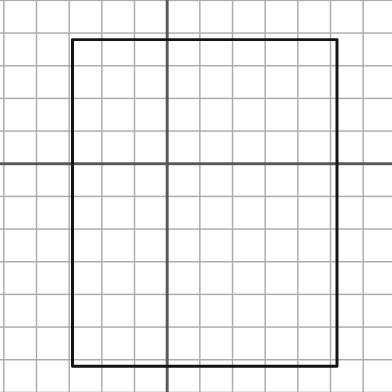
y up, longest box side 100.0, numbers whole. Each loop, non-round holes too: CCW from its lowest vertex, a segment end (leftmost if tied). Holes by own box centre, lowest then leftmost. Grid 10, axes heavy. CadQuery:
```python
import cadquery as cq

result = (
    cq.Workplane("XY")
    .moveTo(-29.0, -62.0)
    .lineTo(52.0, -62.0)
    .lineTo(52.0, 38.0)
    .lineTo(-29.0, 38.0)
    .close()
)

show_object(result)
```